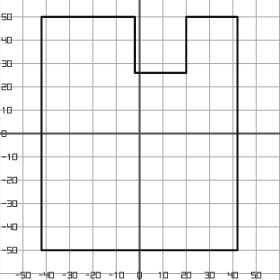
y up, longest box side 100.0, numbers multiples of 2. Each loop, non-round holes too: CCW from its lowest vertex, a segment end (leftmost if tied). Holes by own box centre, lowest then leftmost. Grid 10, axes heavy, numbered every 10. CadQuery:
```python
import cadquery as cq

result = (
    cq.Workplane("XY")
    .moveTo(-42.0, -50.0)
    .lineTo(42.0, -50.0)
    .lineTo(42.0, 50.0)
    .lineTo(20.0, 50.0)
    .lineTo(20.0, 26.0)
    .lineTo(-2.0, 26.0)
    .lineTo(-2.0, 50.0)
    .lineTo(-42.0, 50.0)
    .close()
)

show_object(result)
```